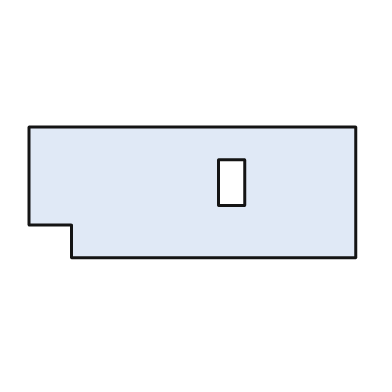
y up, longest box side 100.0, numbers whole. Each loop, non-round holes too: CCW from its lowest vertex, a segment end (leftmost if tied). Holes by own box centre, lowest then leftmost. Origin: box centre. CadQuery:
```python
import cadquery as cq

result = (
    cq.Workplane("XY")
    .moveTo(-37.0, -20.0)
    .lineTo(50.0, -20.0)
    .lineTo(50.0, 20.0)
    .lineTo(-50.0, 20.0)
    .lineTo(-50.0, -10.0)
    .lineTo(-37.0, -10.0)
    .close()
    .moveTo(8.0, -4.0)
    .lineTo(16.0, -4.0)
    .lineTo(16.0, 10.0)
    .lineTo(8.0, 10.0)
    .close()
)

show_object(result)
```